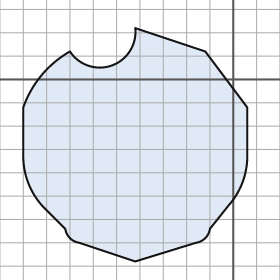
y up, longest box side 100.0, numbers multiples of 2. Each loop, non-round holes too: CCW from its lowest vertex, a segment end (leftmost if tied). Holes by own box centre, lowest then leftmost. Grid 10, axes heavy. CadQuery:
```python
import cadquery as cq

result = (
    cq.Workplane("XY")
    .moveTo(-42.0, -78.0)
    .lineTo(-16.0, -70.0)
    .threePointArc((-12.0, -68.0), (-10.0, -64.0))
    .lineTo(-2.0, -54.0)
    .threePointArc((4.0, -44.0), (6.0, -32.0))
    .lineTo(6.0, -12.0)
    .lineTo(-12.0, 12.0)
    .lineTo(-42.0, 22.0)
    .threePointArc((-52.0, 6.0), (-70.0, 12.0))
    .threePointArc((-82.0, 2.0), (-90.0, -12.0))
    .lineTo(-90.0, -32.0)
    .threePointArc((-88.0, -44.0), (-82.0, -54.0))
    .lineTo(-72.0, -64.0)
    .threePointArc((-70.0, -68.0), (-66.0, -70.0))
    .close()
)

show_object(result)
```